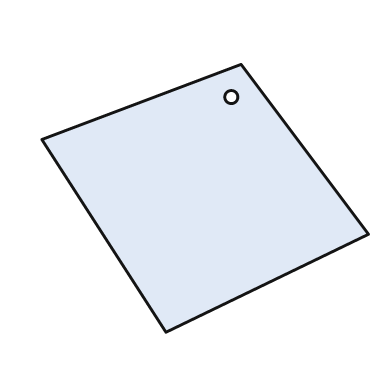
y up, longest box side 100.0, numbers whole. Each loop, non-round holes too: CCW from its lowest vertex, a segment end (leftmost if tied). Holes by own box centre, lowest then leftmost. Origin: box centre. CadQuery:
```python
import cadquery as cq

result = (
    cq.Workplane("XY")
    .moveTo(-12.0, -41.0)
    .lineTo(50.0, -11.0)
    .lineTo(11.0, 41.0)
    .lineTo(-50.0, 18.0)
    .close()
    .moveTo(8.0, 31.0)
    .circle(2.0)
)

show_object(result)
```